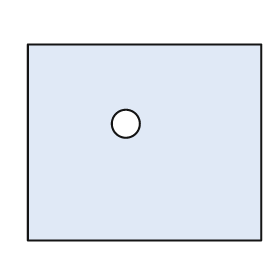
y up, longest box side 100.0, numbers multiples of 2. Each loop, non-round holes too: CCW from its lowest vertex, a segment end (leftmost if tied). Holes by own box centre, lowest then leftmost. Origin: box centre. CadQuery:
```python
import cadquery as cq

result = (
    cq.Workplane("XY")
    .moveTo(-50.0, -42.0)
    .lineTo(50.0, -42.0)
    .lineTo(50.0, 42.0)
    .lineTo(-50.0, 42.0)
    .close()
    .moveTo(-8.0, 8.0)
    .circle(6.0)
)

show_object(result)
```